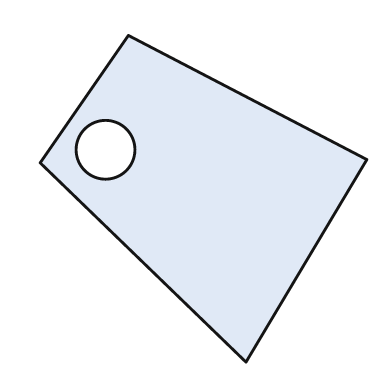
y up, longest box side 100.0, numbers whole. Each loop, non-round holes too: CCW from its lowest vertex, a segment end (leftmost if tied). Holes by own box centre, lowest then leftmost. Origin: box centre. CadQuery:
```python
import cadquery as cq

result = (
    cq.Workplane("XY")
    .moveTo(13.0, -50.0)
    .lineTo(50.0, 12.0)
    .lineTo(-23.0, 50.0)
    .lineTo(-50.0, 11.0)
    .close()
    .moveTo(-30.0, 15.0)
    .circle(9.0)
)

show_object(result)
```